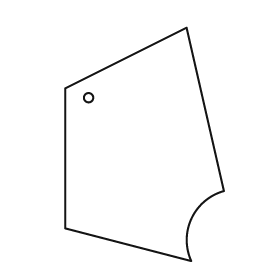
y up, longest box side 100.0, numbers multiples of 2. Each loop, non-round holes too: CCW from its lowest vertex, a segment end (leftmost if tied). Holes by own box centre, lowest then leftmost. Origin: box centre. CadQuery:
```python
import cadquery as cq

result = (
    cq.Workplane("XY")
    .moveTo(20.0, -50.0)
    .threePointArc((20.0, -32.0), (34.0, -20.0))
    .lineTo(18.0, 50.0)
    .lineTo(-34.0, 24.0)
    .lineTo(-34.0, -36.0)
    .close()
    .moveTo(-24.0, 20.0)
    .circle(2.0)
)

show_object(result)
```